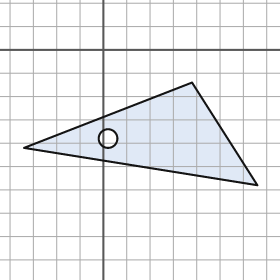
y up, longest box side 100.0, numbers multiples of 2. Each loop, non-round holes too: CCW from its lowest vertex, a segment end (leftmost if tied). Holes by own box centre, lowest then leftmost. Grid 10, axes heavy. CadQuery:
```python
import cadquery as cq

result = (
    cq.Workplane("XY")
    .moveTo(66.0, -58.0)
    .lineTo(38.0, -14.0)
    .lineTo(-34.0, -42.0)
    .close()
    .moveTo(2.0, -38.0)
    .circle(4.0)
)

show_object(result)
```